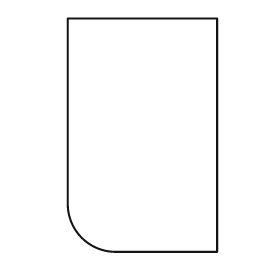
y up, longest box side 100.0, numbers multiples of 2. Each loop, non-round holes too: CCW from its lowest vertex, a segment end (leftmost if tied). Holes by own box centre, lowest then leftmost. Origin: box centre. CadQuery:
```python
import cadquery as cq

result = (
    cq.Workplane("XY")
    .moveTo(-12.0, -50.0)
    .lineTo(32.0, -50.0)
    .lineTo(32.0, 50.0)
    .lineTo(-32.0, 50.0)
    .lineTo(-32.0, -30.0)
    .threePointArc((-26.0, -44.0), (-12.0, -50.0))
    .close()
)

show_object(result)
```